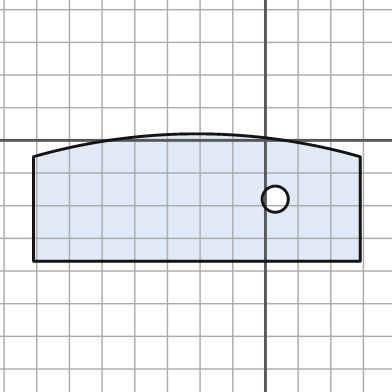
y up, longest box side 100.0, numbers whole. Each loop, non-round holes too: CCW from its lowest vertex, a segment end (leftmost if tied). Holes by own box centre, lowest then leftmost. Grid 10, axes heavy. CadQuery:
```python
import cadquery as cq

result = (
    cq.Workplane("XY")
    .moveTo(-71.0, -37.0)
    .lineTo(29.0, -37.0)
    .lineTo(29.0, -5.0)
    .threePointArc((-21.0, 2.0), (-71.0, -5.0))
    .close()
    .moveTo(3.0, -18.0)
    .circle(4.0)
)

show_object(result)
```